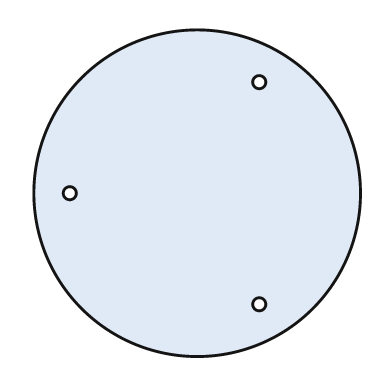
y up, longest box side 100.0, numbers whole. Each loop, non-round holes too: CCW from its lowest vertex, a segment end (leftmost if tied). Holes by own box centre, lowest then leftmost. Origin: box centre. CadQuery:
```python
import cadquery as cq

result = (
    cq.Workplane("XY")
    .moveTo(0.0, 0.0)
    .circle(50.0)
    .moveTo(19.0, -34.0)
    .circle(2.0)
    .moveTo(-39.0, 0.0)
    .circle(2.0)
    .moveTo(19.0, 34.0)
    .circle(2.0)
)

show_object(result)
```